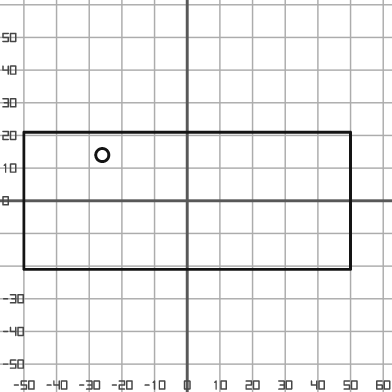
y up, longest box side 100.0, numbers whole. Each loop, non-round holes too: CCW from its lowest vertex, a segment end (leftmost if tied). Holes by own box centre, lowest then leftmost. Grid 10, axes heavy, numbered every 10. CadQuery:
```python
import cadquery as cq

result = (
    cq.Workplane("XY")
    .moveTo(-50.0, -21.0)
    .lineTo(50.0, -21.0)
    .lineTo(50.0, 21.0)
    .lineTo(-50.0, 21.0)
    .close()
    .moveTo(-26.0, 14.0)
    .circle(2.0)
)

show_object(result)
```